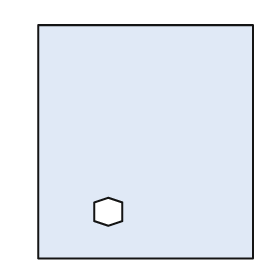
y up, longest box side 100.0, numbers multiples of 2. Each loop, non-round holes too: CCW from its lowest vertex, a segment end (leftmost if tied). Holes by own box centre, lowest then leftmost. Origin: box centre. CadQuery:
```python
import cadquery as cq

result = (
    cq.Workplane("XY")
    .moveTo(-46.0, -50.0)
    .lineTo(46.0, -50.0)
    .lineTo(46.0, 50.0)
    .lineTo(-46.0, 50.0)
    .close()
    .moveTo(-16.0, -36.0)
    .lineTo(-10.0, -34.0)
    .lineTo(-10.0, -26.0)
    .lineTo(-16.0, -24.0)
    .lineTo(-22.0, -26.0)
    .lineTo(-22.0, -34.0)
    .close()
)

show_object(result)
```